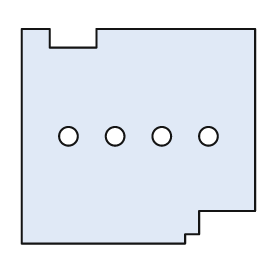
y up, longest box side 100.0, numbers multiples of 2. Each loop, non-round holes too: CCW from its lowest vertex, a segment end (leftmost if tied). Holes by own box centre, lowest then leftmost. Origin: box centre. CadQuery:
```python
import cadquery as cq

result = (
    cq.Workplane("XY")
    .moveTo(-50.0, -46.0)
    .lineTo(20.0, -46.0)
    .lineTo(20.0, -42.0)
    .lineTo(26.0, -42.0)
    .lineTo(26.0, -32.0)
    .lineTo(50.0, -32.0)
    .lineTo(50.0, 46.0)
    .lineTo(-18.0, 46.0)
    .lineTo(-18.0, 38.0)
    .lineTo(-38.0, 38.0)
    .lineTo(-38.0, 46.0)
    .lineTo(-50.0, 46.0)
    .close()
    .moveTo(-30.0, 0.0)
    .circle(4.0)
    .moveTo(-10.0, 0.0)
    .circle(4.0)
    .moveTo(10.0, 0.0)
    .circle(4.0)
    .moveTo(30.0, 0.0)
    .circle(4.0)
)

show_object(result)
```